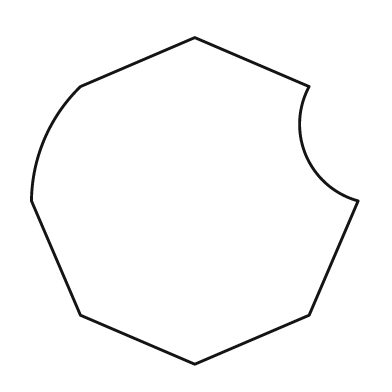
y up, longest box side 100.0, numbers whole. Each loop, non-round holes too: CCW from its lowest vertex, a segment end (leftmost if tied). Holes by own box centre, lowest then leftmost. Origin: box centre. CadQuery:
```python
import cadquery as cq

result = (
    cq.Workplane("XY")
    .moveTo(0.0, -50.0)
    .lineTo(35.0, -35.0)
    .lineTo(50.0, 0.0)
    .threePointArc((34.0, 14.0), (35.0, 35.0))
    .lineTo(0.0, 50.0)
    .lineTo(-35.0, 35.0)
    .threePointArc((-46.0, 19.0), (-50.0, 0.0))
    .lineTo(-35.0, -35.0)
    .close()
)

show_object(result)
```